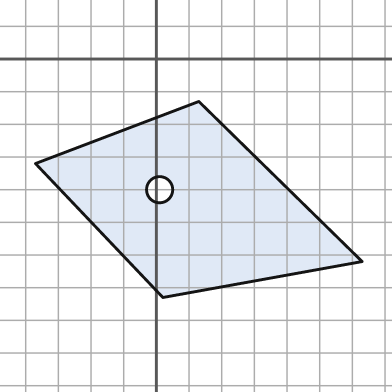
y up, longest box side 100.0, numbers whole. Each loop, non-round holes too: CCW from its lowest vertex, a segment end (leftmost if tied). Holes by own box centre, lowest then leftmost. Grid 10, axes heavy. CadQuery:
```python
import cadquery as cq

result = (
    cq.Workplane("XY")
    .moveTo(2.0, -73.0)
    .lineTo(63.0, -62.0)
    .lineTo(13.0, -13.0)
    .lineTo(-37.0, -32.0)
    .close()
    .moveTo(1.0, -40.0)
    .circle(4.0)
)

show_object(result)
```